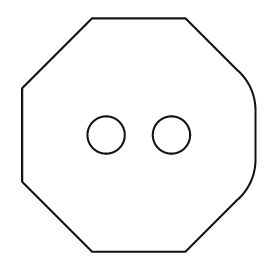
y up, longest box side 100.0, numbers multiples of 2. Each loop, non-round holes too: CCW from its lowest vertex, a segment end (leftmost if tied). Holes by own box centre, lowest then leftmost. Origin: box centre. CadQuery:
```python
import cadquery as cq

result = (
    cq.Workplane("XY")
    .moveTo(-20.0, -50.0)
    .lineTo(20.0, -50.0)
    .lineTo(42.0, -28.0)
    .threePointArc((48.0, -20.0), (50.0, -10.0))
    .lineTo(50.0, 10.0)
    .threePointArc((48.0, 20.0), (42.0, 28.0))
    .lineTo(20.0, 50.0)
    .lineTo(-20.0, 50.0)
    .lineTo(-50.0, 20.0)
    .lineTo(-50.0, -20.0)
    .close()
    .moveTo(-14.0, 0.0)
    .circle(8.0)
    .moveTo(14.0, 0.0)
    .circle(8.0)
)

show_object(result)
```